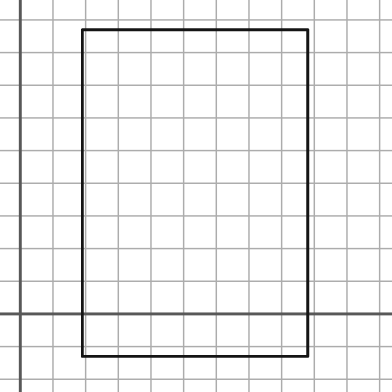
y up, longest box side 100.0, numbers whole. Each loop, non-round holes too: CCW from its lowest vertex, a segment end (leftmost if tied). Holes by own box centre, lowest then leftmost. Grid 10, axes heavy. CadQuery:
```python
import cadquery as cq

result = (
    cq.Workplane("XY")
    .moveTo(19.0, -13.0)
    .lineTo(88.0, -13.0)
    .lineTo(88.0, 87.0)
    .lineTo(19.0, 87.0)
    .close()
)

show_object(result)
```